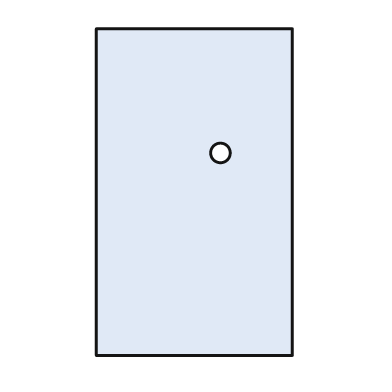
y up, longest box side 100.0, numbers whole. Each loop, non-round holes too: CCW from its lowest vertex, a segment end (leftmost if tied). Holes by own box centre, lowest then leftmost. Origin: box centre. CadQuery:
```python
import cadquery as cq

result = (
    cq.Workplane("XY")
    .moveTo(-30.0, -50.0)
    .lineTo(30.0, -50.0)
    .lineTo(30.0, 50.0)
    .lineTo(-30.0, 50.0)
    .close()
    .moveTo(8.0, 12.0)
    .circle(3.0)
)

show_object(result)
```